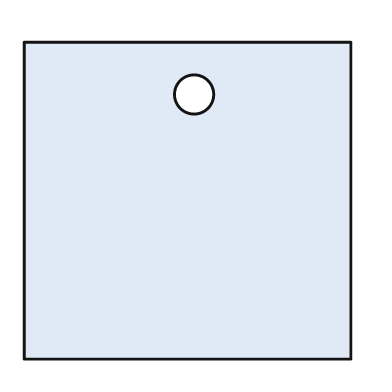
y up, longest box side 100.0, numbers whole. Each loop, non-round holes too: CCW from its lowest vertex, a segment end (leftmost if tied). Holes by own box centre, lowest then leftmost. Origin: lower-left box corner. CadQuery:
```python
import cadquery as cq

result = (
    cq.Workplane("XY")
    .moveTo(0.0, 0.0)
    .lineTo(100.0, 0.0)
    .lineTo(100.0, 97.0)
    .lineTo(0.0, 97.0)
    .close()
    .moveTo(52.0, 81.0)
    .circle(6.0)
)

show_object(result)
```